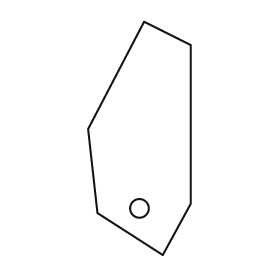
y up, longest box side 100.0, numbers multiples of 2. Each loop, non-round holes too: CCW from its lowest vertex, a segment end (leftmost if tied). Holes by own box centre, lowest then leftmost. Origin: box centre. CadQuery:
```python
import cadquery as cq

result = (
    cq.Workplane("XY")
    .moveTo(10.0, -50.0)
    .lineTo(22.0, -28.0)
    .lineTo(22.0, 40.0)
    .lineTo(2.0, 50.0)
    .lineTo(-22.0, 4.0)
    .lineTo(-18.0, -32.0)
    .close()
    .moveTo(0.0, -30.0)
    .circle(4.0)
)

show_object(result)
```